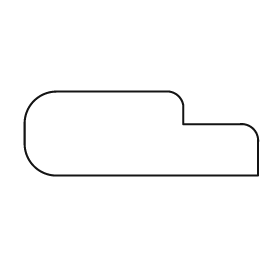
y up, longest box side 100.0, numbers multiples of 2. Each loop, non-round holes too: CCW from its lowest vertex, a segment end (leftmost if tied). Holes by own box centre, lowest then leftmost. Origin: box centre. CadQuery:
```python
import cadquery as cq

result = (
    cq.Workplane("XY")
    .moveTo(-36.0, -18.0)
    .lineTo(50.0, -18.0)
    .lineTo(50.0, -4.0)
    .threePointArc((48.0, 2.0), (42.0, 4.0))
    .lineTo(18.0, 4.0)
    .lineTo(18.0, 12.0)
    .threePointArc((16.0, 16.0), (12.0, 18.0))
    .lineTo(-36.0, 18.0)
    .threePointArc((-46.0, 14.0), (-50.0, 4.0))
    .lineTo(-50.0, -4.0)
    .threePointArc((-46.0, -14.0), (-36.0, -18.0))
    .close()
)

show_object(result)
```